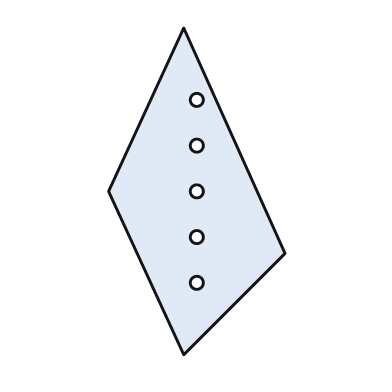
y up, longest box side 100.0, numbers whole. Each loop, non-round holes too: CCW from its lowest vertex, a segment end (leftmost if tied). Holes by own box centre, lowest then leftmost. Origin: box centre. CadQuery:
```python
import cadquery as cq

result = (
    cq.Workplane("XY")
    .moveTo(-4.0, -50.0)
    .lineTo(27.0, -19.0)
    .lineTo(-4.0, 50.0)
    .lineTo(-27.0, 0.0)
    .close()
    .moveTo(0.0, -28.0)
    .circle(2.0)
    .moveTo(0.0, -14.0)
    .circle(2.0)
    .moveTo(0.0, 0.0)
    .circle(2.0)
    .moveTo(0.0, 14.0)
    .circle(2.0)
    .moveTo(0.0, 28.0)
    .circle(2.0)
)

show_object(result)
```